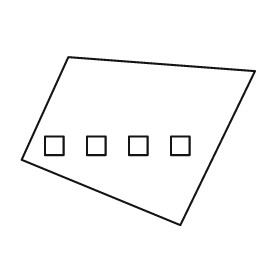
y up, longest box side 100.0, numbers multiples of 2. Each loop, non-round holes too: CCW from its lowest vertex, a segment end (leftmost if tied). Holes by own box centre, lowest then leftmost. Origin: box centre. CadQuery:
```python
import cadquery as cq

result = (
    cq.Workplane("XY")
    .moveTo(18.0, -36.0)
    .lineTo(50.0, 30.0)
    .lineTo(-30.0, 36.0)
    .lineTo(-50.0, -8.0)
    .close()
    .moveTo(-40.0, -6.0)
    .lineTo(-32.0, -6.0)
    .lineTo(-32.0, 2.0)
    .lineTo(-40.0, 2.0)
    .close()
    .moveTo(-22.0, -6.0)
    .lineTo(-14.0, -6.0)
    .lineTo(-14.0, 2.0)
    .lineTo(-22.0, 2.0)
    .close()
    .moveTo(-4.0, -6.0)
    .lineTo(4.0, -6.0)
    .lineTo(4.0, 2.0)
    .lineTo(-4.0, 2.0)
    .close()
    .moveTo(14.0, -6.0)
    .lineTo(22.0, -6.0)
    .lineTo(22.0, 2.0)
    .lineTo(14.0, 2.0)
    .close()
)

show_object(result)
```